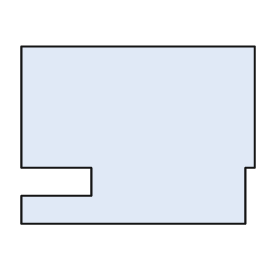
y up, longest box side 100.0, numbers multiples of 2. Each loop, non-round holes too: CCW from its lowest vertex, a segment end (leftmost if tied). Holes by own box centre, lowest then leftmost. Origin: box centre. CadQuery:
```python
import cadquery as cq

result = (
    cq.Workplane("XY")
    .moveTo(-50.0, -38.0)
    .lineTo(46.0, -38.0)
    .lineTo(46.0, -14.0)
    .lineTo(50.0, -14.0)
    .lineTo(50.0, 38.0)
    .lineTo(-50.0, 38.0)
    .lineTo(-50.0, -14.0)
    .lineTo(-20.0, -14.0)
    .lineTo(-20.0, -26.0)
    .lineTo(-50.0, -26.0)
    .close()
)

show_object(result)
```